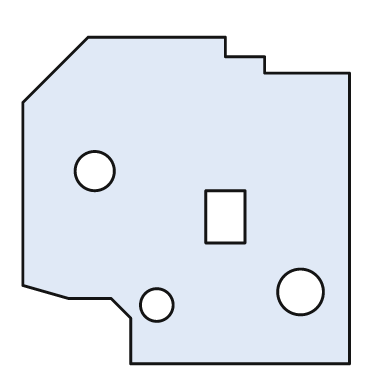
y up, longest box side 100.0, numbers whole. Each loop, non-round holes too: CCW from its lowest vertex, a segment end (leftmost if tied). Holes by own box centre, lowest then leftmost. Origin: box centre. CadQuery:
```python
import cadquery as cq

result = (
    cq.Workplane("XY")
    .moveTo(-17.0, -50.0)
    .lineTo(50.0, -50.0)
    .lineTo(50.0, 39.0)
    .lineTo(24.0, 39.0)
    .lineTo(24.0, 44.0)
    .lineTo(12.0, 44.0)
    .lineTo(12.0, 50.0)
    .lineTo(-30.0, 50.0)
    .lineTo(-50.0, 30.0)
    .lineTo(-50.0, -26.0)
    .lineTo(-36.0, -30.0)
    .lineTo(-23.0, -30.0)
    .lineTo(-17.0, -36.0)
    .close()
    .moveTo(-9.0, -32.0)
    .circle(5.0)
    .moveTo(35.0, -28.0)
    .circle(7.0)
    .moveTo(6.0, -13.0)
    .lineTo(18.0, -13.0)
    .lineTo(18.0, 3.0)
    .lineTo(6.0, 3.0)
    .close()
    .moveTo(-28.0, 9.0)
    .circle(6.0)
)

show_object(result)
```